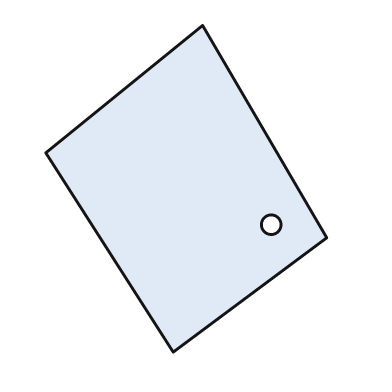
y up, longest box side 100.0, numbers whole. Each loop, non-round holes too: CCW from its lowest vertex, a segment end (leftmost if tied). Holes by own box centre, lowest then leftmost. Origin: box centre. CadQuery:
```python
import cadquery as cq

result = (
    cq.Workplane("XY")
    .moveTo(-4.0, -50.0)
    .lineTo(43.0, -15.0)
    .lineTo(5.0, 50.0)
    .lineTo(-43.0, 11.0)
    .close()
    .moveTo(26.0, -11.0)
    .circle(3.0)
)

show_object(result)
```